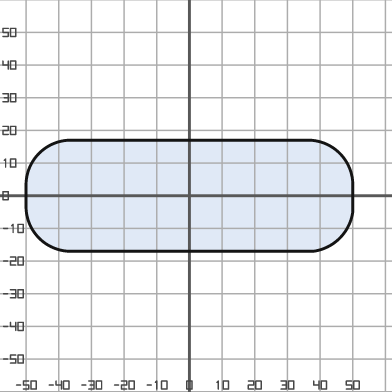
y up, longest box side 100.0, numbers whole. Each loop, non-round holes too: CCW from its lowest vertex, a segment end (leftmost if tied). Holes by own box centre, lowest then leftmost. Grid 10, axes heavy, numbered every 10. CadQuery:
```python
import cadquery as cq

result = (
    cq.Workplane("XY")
    .moveTo(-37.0, -17.0)
    .lineTo(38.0, -17.0)
    .threePointArc((46.0, -13.0), (50.0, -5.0))
    .lineTo(50.0, 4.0)
    .threePointArc((46.0, 13.0), (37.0, 17.0))
    .lineTo(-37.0, 17.0)
    .threePointArc((-46.0, 13.0), (-50.0, 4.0))
    .lineTo(-50.0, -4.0)
    .threePointArc((-46.0, -13.0), (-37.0, -17.0))
    .close()
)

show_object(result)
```